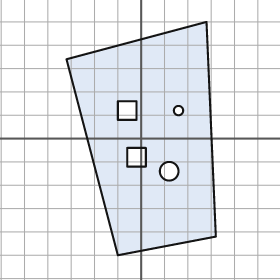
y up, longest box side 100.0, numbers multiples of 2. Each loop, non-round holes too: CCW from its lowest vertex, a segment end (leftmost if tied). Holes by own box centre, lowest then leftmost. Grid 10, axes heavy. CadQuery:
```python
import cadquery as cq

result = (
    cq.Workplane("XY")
    .moveTo(-10.0, -50.0)
    .lineTo(32.0, -42.0)
    .lineTo(28.0, 50.0)
    .lineTo(-32.0, 34.0)
    .close()
    .moveTo(12.0, -14.0)
    .circle(4.0)
    .moveTo(-6.0, -12.0)
    .lineTo(2.0, -12.0)
    .lineTo(2.0, -4.0)
    .lineTo(-6.0, -4.0)
    .close()
    .moveTo(-10.0, 8.0)
    .lineTo(-2.0, 8.0)
    .lineTo(-2.0, 16.0)
    .lineTo(-10.0, 16.0)
    .close()
    .moveTo(16.0, 12.0)
    .circle(2.0)
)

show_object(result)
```